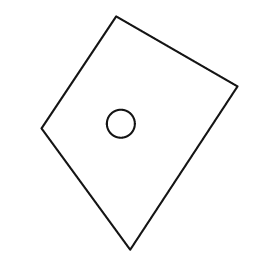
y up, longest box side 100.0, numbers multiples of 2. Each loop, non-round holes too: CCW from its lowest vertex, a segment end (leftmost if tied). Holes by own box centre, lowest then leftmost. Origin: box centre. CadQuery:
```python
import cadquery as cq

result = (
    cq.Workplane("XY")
    .moveTo(-4.0, -50.0)
    .lineTo(42.0, 20.0)
    .lineTo(-10.0, 50.0)
    .lineTo(-42.0, 2.0)
    .close()
    .moveTo(-8.0, 4.0)
    .circle(6.0)
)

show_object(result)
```